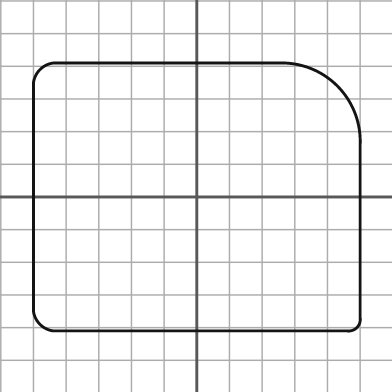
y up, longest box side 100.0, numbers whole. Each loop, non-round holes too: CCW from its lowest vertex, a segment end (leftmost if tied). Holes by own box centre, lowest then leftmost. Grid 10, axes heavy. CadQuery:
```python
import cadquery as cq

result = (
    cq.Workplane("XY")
    .moveTo(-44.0, -41.0)
    .lineTo(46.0, -41.0)
    .threePointArc((49.0, -40.0), (50.0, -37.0))
    .lineTo(50.0, 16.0)
    .threePointArc((43.0, 34.0), (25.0, 41.0))
    .lineTo(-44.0, 41.0)
    .threePointArc((-48.0, 39.0), (-50.0, 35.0))
    .lineTo(-50.0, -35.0)
    .threePointArc((-48.0, -39.0), (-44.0, -41.0))
    .close()
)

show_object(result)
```